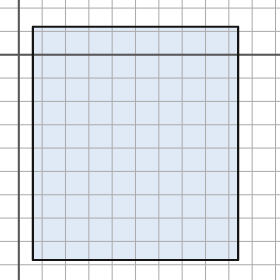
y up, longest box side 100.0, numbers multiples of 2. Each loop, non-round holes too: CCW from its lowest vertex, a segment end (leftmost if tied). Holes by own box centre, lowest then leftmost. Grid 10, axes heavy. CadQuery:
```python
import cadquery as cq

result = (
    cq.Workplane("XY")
    .moveTo(6.0, -88.0)
    .lineTo(94.0, -88.0)
    .lineTo(94.0, 12.0)
    .lineTo(6.0, 12.0)
    .close()
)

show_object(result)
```